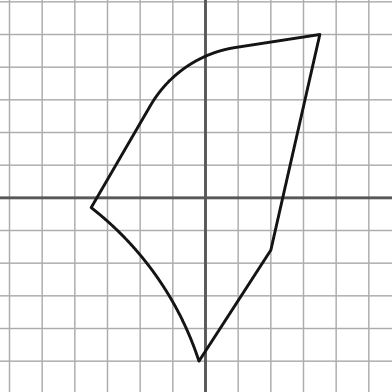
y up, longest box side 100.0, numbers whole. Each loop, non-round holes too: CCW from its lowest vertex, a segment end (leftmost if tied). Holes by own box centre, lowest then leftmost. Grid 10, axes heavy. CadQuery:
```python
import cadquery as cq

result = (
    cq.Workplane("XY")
    .moveTo(-2.0, -50.0)
    .lineTo(20.0, -16.0)
    .lineTo(35.0, 50.0)
    .lineTo(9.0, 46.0)
    .threePointArc((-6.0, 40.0), (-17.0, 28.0))
    .lineTo(-35.0, -3.0)
    .threePointArc((-15.0, -24.0), (-2.0, -50.0))
    .close()
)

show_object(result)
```